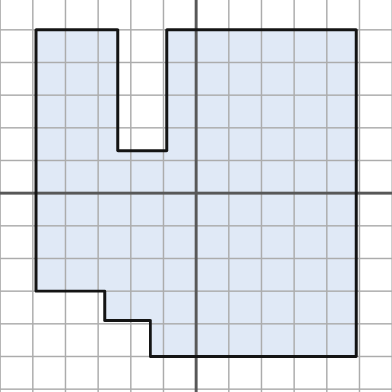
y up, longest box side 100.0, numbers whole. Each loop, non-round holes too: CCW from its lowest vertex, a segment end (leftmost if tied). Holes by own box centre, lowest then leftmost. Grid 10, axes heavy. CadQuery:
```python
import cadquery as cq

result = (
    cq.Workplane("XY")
    .moveTo(-14.0, -50.0)
    .lineTo(49.0, -50.0)
    .lineTo(49.0, 50.0)
    .lineTo(-9.0, 50.0)
    .lineTo(-9.0, 13.0)
    .lineTo(-24.0, 13.0)
    .lineTo(-24.0, 50.0)
    .lineTo(-49.0, 50.0)
    .lineTo(-49.0, -30.0)
    .lineTo(-28.0, -30.0)
    .lineTo(-28.0, -39.0)
    .lineTo(-14.0, -39.0)
    .close()
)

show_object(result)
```